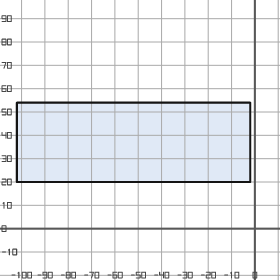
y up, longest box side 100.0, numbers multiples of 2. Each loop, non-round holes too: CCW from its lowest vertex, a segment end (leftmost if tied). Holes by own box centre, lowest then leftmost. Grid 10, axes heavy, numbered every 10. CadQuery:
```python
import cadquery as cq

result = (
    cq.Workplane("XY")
    .moveTo(-102.0, 20.0)
    .lineTo(-2.0, 20.0)
    .lineTo(-2.0, 54.0)
    .lineTo(-102.0, 54.0)
    .close()
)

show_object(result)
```